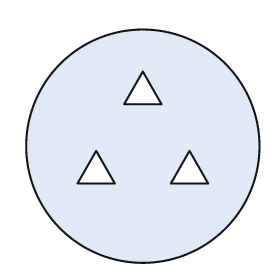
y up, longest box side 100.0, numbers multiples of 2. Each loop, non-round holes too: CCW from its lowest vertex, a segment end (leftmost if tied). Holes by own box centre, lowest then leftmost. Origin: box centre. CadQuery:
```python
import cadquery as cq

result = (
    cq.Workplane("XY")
    .moveTo(0.0, 0.0)
    .circle(50.0)
    .moveTo(-28.0, -16.0)
    .lineTo(-12.0, -16.0)
    .lineTo(-20.0, -2.0)
    .close()
    .moveTo(12.0, -16.0)
    .lineTo(28.0, -16.0)
    .lineTo(20.0, -2.0)
    .close()
    .moveTo(-8.0, 18.0)
    .lineTo(8.0, 18.0)
    .lineTo(0.0, 32.0)
    .close()
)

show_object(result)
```